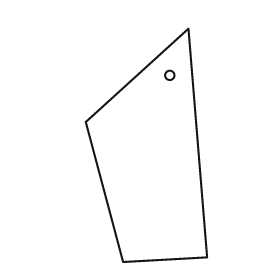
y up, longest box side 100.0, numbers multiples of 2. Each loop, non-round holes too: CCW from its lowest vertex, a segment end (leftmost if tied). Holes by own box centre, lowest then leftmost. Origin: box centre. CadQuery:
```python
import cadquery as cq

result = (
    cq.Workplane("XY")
    .moveTo(-10.0, -50.0)
    .lineTo(26.0, -48.0)
    .lineTo(18.0, 50.0)
    .lineTo(-26.0, 10.0)
    .close()
    .moveTo(10.0, 30.0)
    .circle(2.0)
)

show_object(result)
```